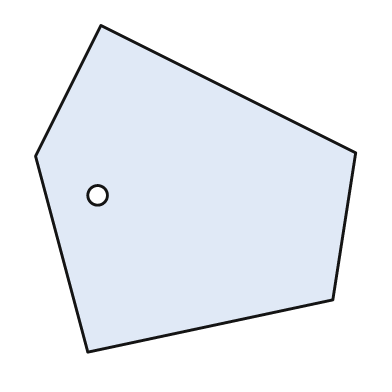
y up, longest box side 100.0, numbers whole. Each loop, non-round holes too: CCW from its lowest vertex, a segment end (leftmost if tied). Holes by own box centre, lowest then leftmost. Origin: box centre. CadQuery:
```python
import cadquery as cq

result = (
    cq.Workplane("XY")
    .moveTo(-33.0, -50.0)
    .lineTo(42.0, -34.0)
    .lineTo(49.0, 11.0)
    .lineTo(-29.0, 50.0)
    .lineTo(-49.0, 10.0)
    .close()
    .moveTo(-30.0, -2.0)
    .circle(3.0)
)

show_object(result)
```